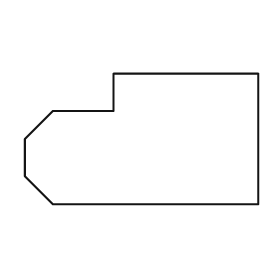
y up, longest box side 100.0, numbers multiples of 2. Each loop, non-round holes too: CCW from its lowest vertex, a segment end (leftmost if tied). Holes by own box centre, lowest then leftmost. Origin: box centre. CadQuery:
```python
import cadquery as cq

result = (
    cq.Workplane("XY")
    .moveTo(-38.0, -28.0)
    .lineTo(50.0, -28.0)
    .lineTo(50.0, 28.0)
    .lineTo(-12.0, 28.0)
    .lineTo(-12.0, 12.0)
    .lineTo(-38.0, 12.0)
    .lineTo(-50.0, 0.0)
    .lineTo(-50.0, -16.0)
    .close()
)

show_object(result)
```